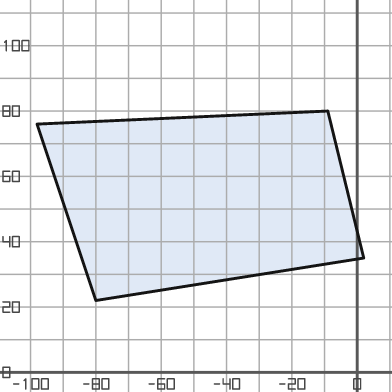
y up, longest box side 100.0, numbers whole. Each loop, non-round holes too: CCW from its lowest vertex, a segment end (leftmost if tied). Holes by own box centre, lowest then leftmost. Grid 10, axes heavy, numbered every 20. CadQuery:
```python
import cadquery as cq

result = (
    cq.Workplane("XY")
    .moveTo(-80.0, 22.0)
    .lineTo(2.0, 35.0)
    .lineTo(-9.0, 80.0)
    .lineTo(-98.0, 76.0)
    .close()
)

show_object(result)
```